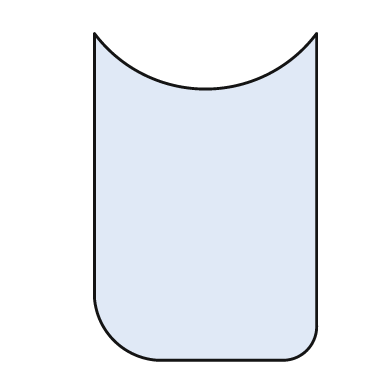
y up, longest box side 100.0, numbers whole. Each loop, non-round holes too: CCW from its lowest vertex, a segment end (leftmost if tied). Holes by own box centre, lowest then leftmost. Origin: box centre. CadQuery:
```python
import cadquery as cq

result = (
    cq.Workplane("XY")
    .moveTo(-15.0, -50.0)
    .lineTo(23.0, -50.0)
    .threePointArc((31.0, -47.0), (34.0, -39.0))
    .lineTo(34.0, 50.0)
    .threePointArc((0.0, 33.0), (-34.0, 50.0))
    .lineTo(-34.0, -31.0)
    .threePointArc((-28.0, -44.0), (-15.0, -50.0))
    .close()
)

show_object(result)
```